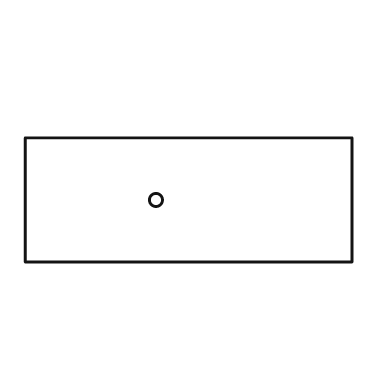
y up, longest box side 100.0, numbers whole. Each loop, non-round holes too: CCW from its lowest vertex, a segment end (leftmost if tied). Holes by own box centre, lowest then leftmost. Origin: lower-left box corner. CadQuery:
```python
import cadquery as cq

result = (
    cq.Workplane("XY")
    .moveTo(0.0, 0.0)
    .lineTo(100.0, 0.0)
    .lineTo(100.0, 38.0)
    .lineTo(0.0, 38.0)
    .close()
    .moveTo(40.0, 19.0)
    .circle(2.0)
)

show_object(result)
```